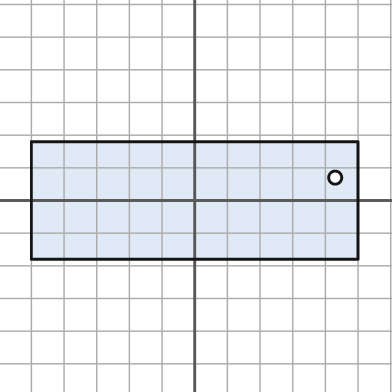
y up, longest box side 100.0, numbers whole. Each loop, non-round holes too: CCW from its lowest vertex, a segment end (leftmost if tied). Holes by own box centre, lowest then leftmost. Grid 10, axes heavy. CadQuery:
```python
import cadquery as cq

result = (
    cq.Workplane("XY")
    .moveTo(-50.0, -18.0)
    .lineTo(50.0, -18.0)
    .lineTo(50.0, 18.0)
    .lineTo(-50.0, 18.0)
    .close()
    .moveTo(43.0, 7.0)
    .circle(2.0)
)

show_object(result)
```